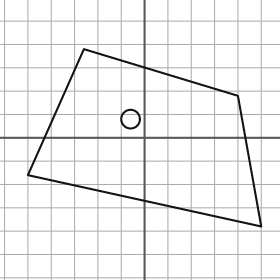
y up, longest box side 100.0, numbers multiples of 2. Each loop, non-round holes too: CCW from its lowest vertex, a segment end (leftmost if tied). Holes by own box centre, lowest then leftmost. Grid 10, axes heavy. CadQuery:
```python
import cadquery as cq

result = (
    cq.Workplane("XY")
    .moveTo(50.0, -38.0)
    .lineTo(40.0, 18.0)
    .lineTo(-26.0, 38.0)
    .lineTo(-50.0, -16.0)
    .close()
    .moveTo(-6.0, 8.0)
    .circle(4.0)
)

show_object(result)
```